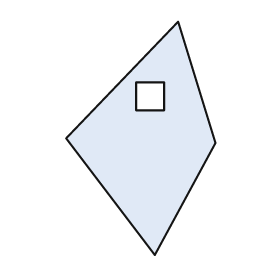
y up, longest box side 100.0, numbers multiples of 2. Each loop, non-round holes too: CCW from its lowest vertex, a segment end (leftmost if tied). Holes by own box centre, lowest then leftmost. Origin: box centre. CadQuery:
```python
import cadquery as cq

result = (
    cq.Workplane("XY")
    .moveTo(6.0, -50.0)
    .lineTo(32.0, -2.0)
    .lineTo(16.0, 50.0)
    .lineTo(-32.0, 0.0)
    .close()
    .moveTo(-2.0, 12.0)
    .lineTo(10.0, 12.0)
    .lineTo(10.0, 24.0)
    .lineTo(-2.0, 24.0)
    .close()
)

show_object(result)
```